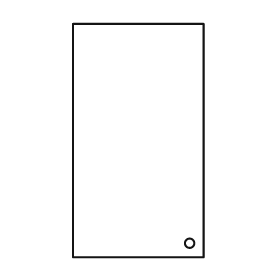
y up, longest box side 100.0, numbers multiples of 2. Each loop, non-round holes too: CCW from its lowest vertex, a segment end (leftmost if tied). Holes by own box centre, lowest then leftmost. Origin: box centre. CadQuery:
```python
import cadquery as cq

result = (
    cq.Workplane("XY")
    .moveTo(-28.0, -50.0)
    .lineTo(28.0, -50.0)
    .lineTo(28.0, 50.0)
    .lineTo(-28.0, 50.0)
    .close()
    .moveTo(22.0, -44.0)
    .circle(2.0)
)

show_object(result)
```